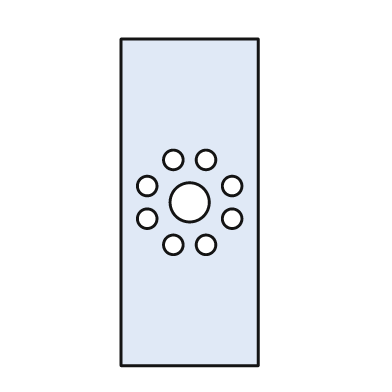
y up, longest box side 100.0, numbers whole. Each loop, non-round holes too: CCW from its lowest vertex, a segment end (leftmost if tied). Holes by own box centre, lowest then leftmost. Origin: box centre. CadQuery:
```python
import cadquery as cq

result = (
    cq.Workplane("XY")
    .moveTo(-21.0, -50.0)
    .lineTo(21.0, -50.0)
    .lineTo(21.0, 50.0)
    .lineTo(-21.0, 50.0)
    .close()
    .moveTo(-5.0, -13.0)
    .circle(3.0)
    .moveTo(5.0, -13.0)
    .circle(3.0)
    .moveTo(-13.0, -5.0)
    .circle(3.0)
    .moveTo(13.0, -5.0)
    .circle(3.0)
    .moveTo(0.0, 0.0)
    .circle(6.0)
    .moveTo(-13.0, 5.0)
    .circle(3.0)
    .moveTo(13.0, 5.0)
    .circle(3.0)
    .moveTo(-5.0, 13.0)
    .circle(3.0)
    .moveTo(5.0, 13.0)
    .circle(3.0)
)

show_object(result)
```